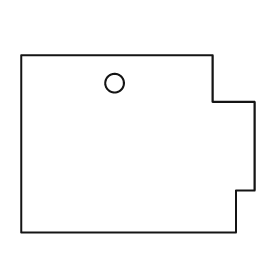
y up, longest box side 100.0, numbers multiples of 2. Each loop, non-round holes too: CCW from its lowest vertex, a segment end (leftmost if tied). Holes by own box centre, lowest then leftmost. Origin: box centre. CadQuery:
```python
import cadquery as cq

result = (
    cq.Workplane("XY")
    .moveTo(-50.0, -38.0)
    .lineTo(42.0, -38.0)
    .lineTo(42.0, -20.0)
    .lineTo(50.0, -20.0)
    .lineTo(50.0, 18.0)
    .lineTo(32.0, 18.0)
    .lineTo(32.0, 38.0)
    .lineTo(-50.0, 38.0)
    .close()
    .moveTo(-10.0, 26.0)
    .circle(4.0)
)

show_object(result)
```